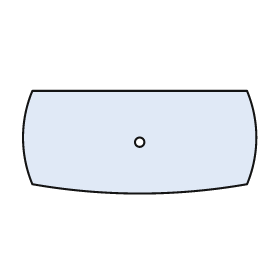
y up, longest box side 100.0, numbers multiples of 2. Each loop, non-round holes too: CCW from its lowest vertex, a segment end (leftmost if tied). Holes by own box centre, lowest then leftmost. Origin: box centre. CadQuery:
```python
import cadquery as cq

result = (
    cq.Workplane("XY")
    .moveTo(-46.0, -18.0)
    .threePointArc((0.0, -22.0), (46.0, -18.0))
    .threePointArc((50.0, 2.0), (46.0, 22.0))
    .lineTo(-46.0, 22.0)
    .threePointArc((-50.0, 2.0), (-46.0, -18.0))
    .close()
    .moveTo(0.0, 0.0)
    .circle(2.0)
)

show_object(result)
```